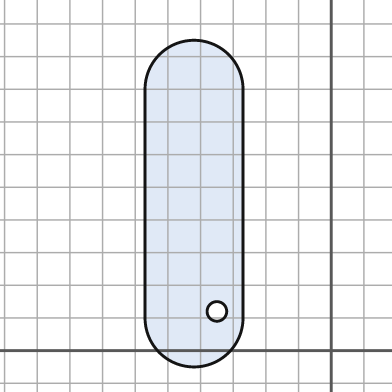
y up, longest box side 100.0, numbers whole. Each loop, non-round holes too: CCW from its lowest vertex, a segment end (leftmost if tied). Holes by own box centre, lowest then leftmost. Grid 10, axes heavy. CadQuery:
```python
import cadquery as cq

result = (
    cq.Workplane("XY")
    .moveTo(-57.0, 10.0)
    .threePointArc((-42.0, -5.0), (-27.0, 10.0))
    .lineTo(-27.0, 80.0)
    .threePointArc((-42.0, 95.0), (-57.0, 80.0))
    .close()
    .moveTo(-35.0, 12.0)
    .circle(3.0)
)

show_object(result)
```